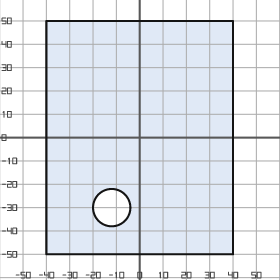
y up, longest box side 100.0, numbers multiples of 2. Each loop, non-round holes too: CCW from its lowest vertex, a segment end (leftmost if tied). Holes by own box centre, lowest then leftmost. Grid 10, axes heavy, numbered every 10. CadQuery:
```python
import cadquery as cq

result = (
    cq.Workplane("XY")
    .moveTo(-40.0, -50.0)
    .lineTo(40.0, -50.0)
    .lineTo(40.0, 50.0)
    .lineTo(-40.0, 50.0)
    .close()
    .moveTo(-12.0, -30.0)
    .circle(8.0)
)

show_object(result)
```